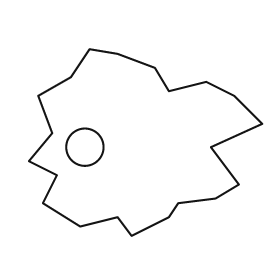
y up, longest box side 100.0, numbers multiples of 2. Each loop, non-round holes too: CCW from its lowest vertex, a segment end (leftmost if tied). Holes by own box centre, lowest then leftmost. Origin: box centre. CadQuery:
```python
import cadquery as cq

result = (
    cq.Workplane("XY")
    .moveTo(-6.0, -40.0)
    .lineTo(10.0, -32.0)
    .lineTo(14.0, -26.0)
    .lineTo(30.0, -24.0)
    .lineTo(40.0, -18.0)
    .lineTo(28.0, -2.0)
    .lineTo(50.0, 8.0)
    .lineTo(38.0, 20.0)
    .lineTo(26.0, 26.0)
    .lineTo(10.0, 22.0)
    .lineTo(4.0, 32.0)
    .lineTo(-12.0, 38.0)
    .lineTo(-24.0, 40.0)
    .lineTo(-32.0, 28.0)
    .lineTo(-46.0, 20.0)
    .lineTo(-40.0, 4.0)
    .lineTo(-50.0, -8.0)
    .lineTo(-38.0, -14.0)
    .lineTo(-44.0, -26.0)
    .lineTo(-28.0, -36.0)
    .lineTo(-12.0, -32.0)
    .close()
    .moveTo(-26.0, -2.0)
    .circle(8.0)
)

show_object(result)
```